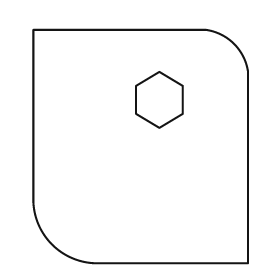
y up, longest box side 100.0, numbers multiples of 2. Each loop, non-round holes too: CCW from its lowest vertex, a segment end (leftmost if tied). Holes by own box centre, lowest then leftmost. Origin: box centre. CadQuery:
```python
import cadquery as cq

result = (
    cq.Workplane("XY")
    .moveTo(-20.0, -50.0)
    .lineTo(46.0, -50.0)
    .lineTo(46.0, 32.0)
    .threePointArc((40.0, 44.0), (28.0, 50.0))
    .lineTo(-46.0, 50.0)
    .lineTo(-46.0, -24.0)
    .threePointArc((-38.0, -42.0), (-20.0, -50.0))
    .close()
    .moveTo(8.0, 8.0)
    .lineTo(18.0, 14.0)
    .lineTo(18.0, 26.0)
    .lineTo(8.0, 32.0)
    .lineTo(-2.0, 26.0)
    .lineTo(-2.0, 14.0)
    .close()
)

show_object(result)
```